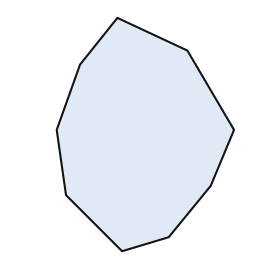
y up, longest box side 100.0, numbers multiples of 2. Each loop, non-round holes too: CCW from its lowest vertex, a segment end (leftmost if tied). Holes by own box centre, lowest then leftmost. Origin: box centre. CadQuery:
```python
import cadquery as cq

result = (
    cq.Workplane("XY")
    .moveTo(-10.0, -50.0)
    .lineTo(10.0, -44.0)
    .lineTo(28.0, -22.0)
    .lineTo(38.0, 2.0)
    .lineTo(18.0, 36.0)
    .lineTo(-12.0, 50.0)
    .lineTo(-28.0, 30.0)
    .lineTo(-38.0, 2.0)
    .lineTo(-34.0, -26.0)
    .close()
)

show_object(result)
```